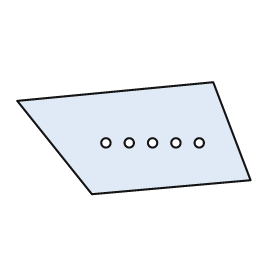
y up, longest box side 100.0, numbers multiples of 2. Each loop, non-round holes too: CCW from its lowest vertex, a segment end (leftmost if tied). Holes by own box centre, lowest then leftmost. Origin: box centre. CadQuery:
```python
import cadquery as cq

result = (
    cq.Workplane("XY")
    .moveTo(-18.0, -24.0)
    .lineTo(50.0, -18.0)
    .lineTo(34.0, 24.0)
    .lineTo(-50.0, 16.0)
    .close()
    .moveTo(-12.0, -2.0)
    .circle(2.0)
    .moveTo(-2.0, -2.0)
    .circle(2.0)
    .moveTo(8.0, -2.0)
    .circle(2.0)
    .moveTo(18.0, -2.0)
    .circle(2.0)
    .moveTo(28.0, -2.0)
    .circle(2.0)
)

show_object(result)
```